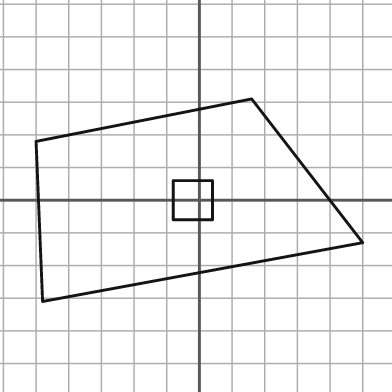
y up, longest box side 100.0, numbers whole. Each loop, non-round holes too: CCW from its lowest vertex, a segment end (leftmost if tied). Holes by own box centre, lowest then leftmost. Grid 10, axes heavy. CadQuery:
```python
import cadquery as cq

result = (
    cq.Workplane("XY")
    .moveTo(-48.0, -31.0)
    .lineTo(50.0, -13.0)
    .lineTo(16.0, 31.0)
    .lineTo(-50.0, 18.0)
    .close()
    .moveTo(-8.0, -6.0)
    .lineTo(4.0, -6.0)
    .lineTo(4.0, 6.0)
    .lineTo(-8.0, 6.0)
    .close()
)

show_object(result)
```